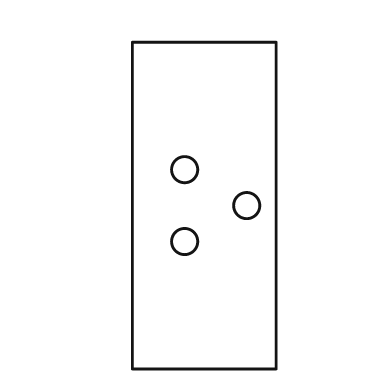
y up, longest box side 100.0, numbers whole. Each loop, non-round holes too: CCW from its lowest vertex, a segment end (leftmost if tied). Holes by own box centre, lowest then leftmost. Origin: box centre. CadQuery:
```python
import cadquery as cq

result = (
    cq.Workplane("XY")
    .moveTo(-22.0, -50.0)
    .lineTo(22.0, -50.0)
    .lineTo(22.0, 50.0)
    .lineTo(-22.0, 50.0)
    .close()
    .moveTo(-6.0, -11.0)
    .circle(4.0)
    .moveTo(13.0, 0.0)
    .circle(4.0)
    .moveTo(-6.0, 11.0)
    .circle(4.0)
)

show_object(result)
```